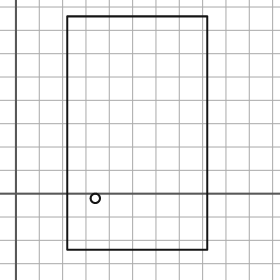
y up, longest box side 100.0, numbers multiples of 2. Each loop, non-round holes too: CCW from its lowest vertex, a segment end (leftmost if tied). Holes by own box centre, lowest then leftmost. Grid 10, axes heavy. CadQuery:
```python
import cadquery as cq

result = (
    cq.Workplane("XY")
    .moveTo(22.0, -24.0)
    .lineTo(82.0, -24.0)
    .lineTo(82.0, 76.0)
    .lineTo(22.0, 76.0)
    .close()
    .moveTo(34.0, -2.0)
    .circle(2.0)
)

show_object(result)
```